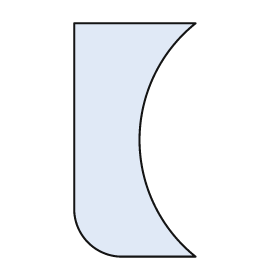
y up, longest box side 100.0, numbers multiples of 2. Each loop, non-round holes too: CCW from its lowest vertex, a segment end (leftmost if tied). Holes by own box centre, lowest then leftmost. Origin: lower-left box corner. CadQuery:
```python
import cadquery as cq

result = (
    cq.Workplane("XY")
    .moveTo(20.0, 0.0)
    .lineTo(52.0, 0.0)
    .threePointArc((28.0, 50.0), (52.0, 100.0))
    .lineTo(0.0, 100.0)
    .lineTo(0.0, 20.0)
    .threePointArc((6.0, 6.0), (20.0, 0.0))
    .close()
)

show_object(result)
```